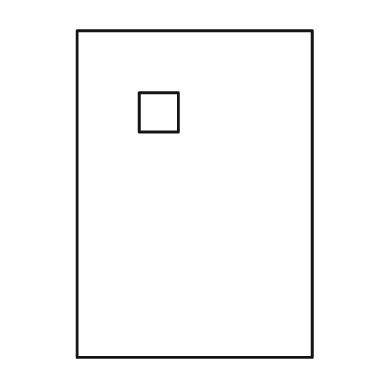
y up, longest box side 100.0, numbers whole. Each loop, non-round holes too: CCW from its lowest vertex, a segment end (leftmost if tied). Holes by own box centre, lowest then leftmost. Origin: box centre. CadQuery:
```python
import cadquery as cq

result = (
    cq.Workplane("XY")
    .moveTo(-36.0, -50.0)
    .lineTo(36.0, -50.0)
    .lineTo(36.0, 50.0)
    .lineTo(-36.0, 50.0)
    .close()
    .moveTo(-17.0, 19.0)
    .lineTo(-5.0, 19.0)
    .lineTo(-5.0, 31.0)
    .lineTo(-17.0, 31.0)
    .close()
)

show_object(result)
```